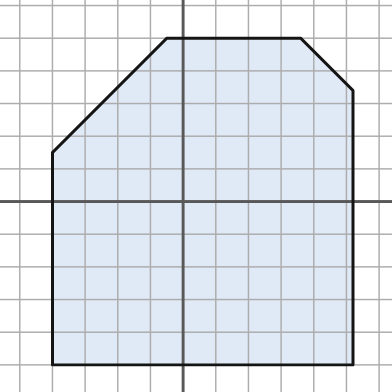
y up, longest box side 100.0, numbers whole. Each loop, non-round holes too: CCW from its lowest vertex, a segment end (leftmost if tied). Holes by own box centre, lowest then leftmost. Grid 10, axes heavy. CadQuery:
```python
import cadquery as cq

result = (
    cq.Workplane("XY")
    .moveTo(-40.0, -50.0)
    .lineTo(52.0, -50.0)
    .lineTo(52.0, 34.0)
    .lineTo(36.0, 50.0)
    .lineTo(-5.0, 50.0)
    .lineTo(-40.0, 15.0)
    .close()
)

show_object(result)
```